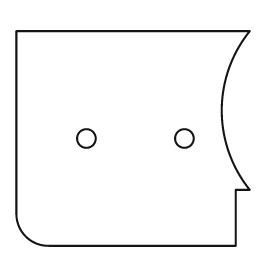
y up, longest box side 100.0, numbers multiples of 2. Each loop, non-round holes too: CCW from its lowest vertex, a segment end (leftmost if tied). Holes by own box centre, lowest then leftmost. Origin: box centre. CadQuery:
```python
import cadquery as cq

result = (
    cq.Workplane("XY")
    .moveTo(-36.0, -46.0)
    .lineTo(44.0, -46.0)
    .lineTo(44.0, -22.0)
    .lineTo(50.0, -22.0)
    .threePointArc((38.0, 12.0), (50.0, 46.0))
    .lineTo(-50.0, 46.0)
    .lineTo(-50.0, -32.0)
    .threePointArc((-46.0, -42.0), (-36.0, -46.0))
    .close()
    .moveTo(-20.0, 0.0)
    .circle(4.0)
    .moveTo(22.0, 0.0)
    .circle(4.0)
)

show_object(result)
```